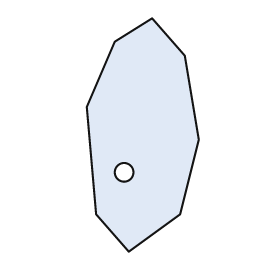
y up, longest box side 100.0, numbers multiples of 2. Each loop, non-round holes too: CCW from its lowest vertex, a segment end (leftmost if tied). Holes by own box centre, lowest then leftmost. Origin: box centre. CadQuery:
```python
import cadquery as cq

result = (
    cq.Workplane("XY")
    .moveTo(-6.0, -50.0)
    .lineTo(16.0, -34.0)
    .lineTo(24.0, -2.0)
    .lineTo(18.0, 34.0)
    .lineTo(4.0, 50.0)
    .lineTo(-12.0, 40.0)
    .lineTo(-24.0, 12.0)
    .lineTo(-20.0, -34.0)
    .close()
    .moveTo(-8.0, -16.0)
    .circle(4.0)
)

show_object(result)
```